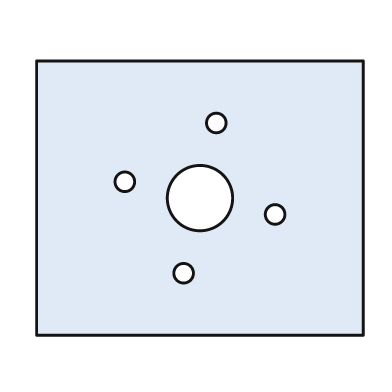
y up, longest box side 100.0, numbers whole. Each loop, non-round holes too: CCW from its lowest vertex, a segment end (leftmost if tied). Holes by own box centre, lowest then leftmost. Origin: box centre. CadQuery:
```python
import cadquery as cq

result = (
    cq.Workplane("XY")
    .moveTo(-50.0, -42.0)
    .lineTo(50.0, -42.0)
    .lineTo(50.0, 42.0)
    .lineTo(-50.0, 42.0)
    .close()
    .moveTo(-5.0, -23.0)
    .circle(3.0)
    .moveTo(23.0, -5.0)
    .circle(3.0)
    .moveTo(0.0, 0.0)
    .circle(10.0)
    .moveTo(-23.0, 5.0)
    .circle(3.0)
    .moveTo(5.0, 23.0)
    .circle(3.0)
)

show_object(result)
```